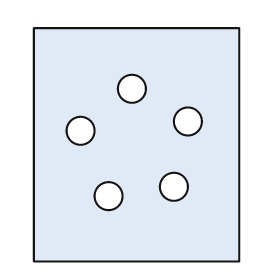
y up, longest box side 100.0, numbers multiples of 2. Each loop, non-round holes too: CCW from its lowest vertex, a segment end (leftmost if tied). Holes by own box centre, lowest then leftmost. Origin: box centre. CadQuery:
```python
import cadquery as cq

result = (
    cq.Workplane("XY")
    .moveTo(-44.0, -50.0)
    .lineTo(44.0, -50.0)
    .lineTo(44.0, 50.0)
    .lineTo(-44.0, 50.0)
    .close()
    .moveTo(-12.0, -22.0)
    .circle(6.0)
    .moveTo(16.0, -18.0)
    .circle(6.0)
    .moveTo(-24.0, 6.0)
    .circle(6.0)
    .moveTo(22.0, 10.0)
    .circle(6.0)
    .moveTo(-2.0, 24.0)
    .circle(6.0)
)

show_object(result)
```